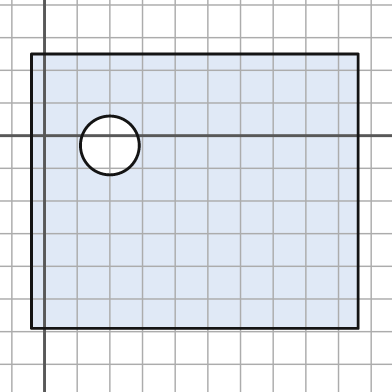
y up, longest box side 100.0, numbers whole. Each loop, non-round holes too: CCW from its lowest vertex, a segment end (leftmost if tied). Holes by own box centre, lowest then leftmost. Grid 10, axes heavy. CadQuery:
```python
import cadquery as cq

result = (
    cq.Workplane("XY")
    .moveTo(-4.0, -59.0)
    .lineTo(96.0, -59.0)
    .lineTo(96.0, 25.0)
    .lineTo(-4.0, 25.0)
    .close()
    .moveTo(20.0, -3.0)
    .circle(9.0)
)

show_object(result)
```